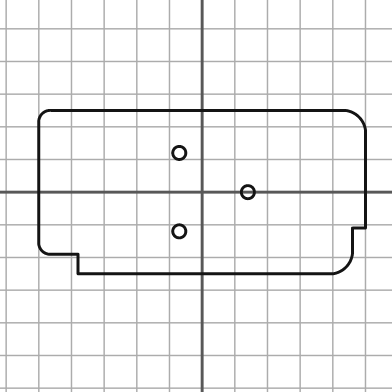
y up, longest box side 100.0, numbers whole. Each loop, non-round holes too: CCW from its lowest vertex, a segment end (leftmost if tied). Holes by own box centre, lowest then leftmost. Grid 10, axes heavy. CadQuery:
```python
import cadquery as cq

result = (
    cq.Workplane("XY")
    .moveTo(-38.0, -25.0)
    .lineTo(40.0, -25.0)
    .threePointArc((44.0, -23.0), (46.0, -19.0))
    .lineTo(46.0, -11.0)
    .lineTo(50.0, -11.0)
    .lineTo(50.0, 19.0)
    .threePointArc((48.0, 23.0), (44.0, 25.0))
    .lineTo(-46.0, 25.0)
    .threePointArc((-49.0, 24.0), (-50.0, 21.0))
    .lineTo(-50.0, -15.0)
    .threePointArc((-49.0, -18.0), (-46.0, -19.0))
    .lineTo(-38.0, -19.0)
    .close()
    .moveTo(-7.0, -12.0)
    .circle(2.0)
    .moveTo(14.0, 0.0)
    .circle(2.0)
    .moveTo(-7.0, 12.0)
    .circle(2.0)
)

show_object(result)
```